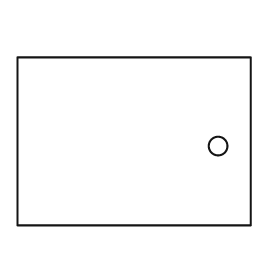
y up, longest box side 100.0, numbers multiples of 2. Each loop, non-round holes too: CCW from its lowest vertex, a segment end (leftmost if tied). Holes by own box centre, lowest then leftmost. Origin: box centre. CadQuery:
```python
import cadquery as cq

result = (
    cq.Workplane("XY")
    .moveTo(-50.0, -36.0)
    .lineTo(50.0, -36.0)
    .lineTo(50.0, 36.0)
    .lineTo(-50.0, 36.0)
    .close()
    .moveTo(36.0, -2.0)
    .circle(4.0)
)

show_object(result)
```